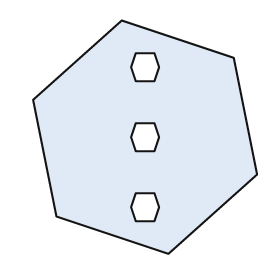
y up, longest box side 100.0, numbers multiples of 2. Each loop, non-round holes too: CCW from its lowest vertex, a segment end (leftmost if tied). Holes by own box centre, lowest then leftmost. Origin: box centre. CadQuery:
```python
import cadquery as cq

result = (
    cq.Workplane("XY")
    .moveTo(10.0, -50.0)
    .lineTo(48.0, -16.0)
    .lineTo(38.0, 34.0)
    .lineTo(-10.0, 50.0)
    .lineTo(-48.0, 16.0)
    .lineTo(-38.0, -34.0)
    .close()
    .moveTo(-4.0, -36.0)
    .lineTo(4.0, -36.0)
    .lineTo(6.0, -30.0)
    .lineTo(4.0, -24.0)
    .lineTo(-4.0, -24.0)
    .lineTo(-6.0, -30.0)
    .close()
    .moveTo(-4.0, -6.0)
    .lineTo(4.0, -6.0)
    .lineTo(6.0, 0.0)
    .lineTo(4.0, 6.0)
    .lineTo(-4.0, 6.0)
    .lineTo(-6.0, 0.0)
    .close()
    .moveTo(-4.0, 24.0)
    .lineTo(4.0, 24.0)
    .lineTo(6.0, 30.0)
    .lineTo(4.0, 36.0)
    .lineTo(-4.0, 36.0)
    .lineTo(-6.0, 30.0)
    .close()
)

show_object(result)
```